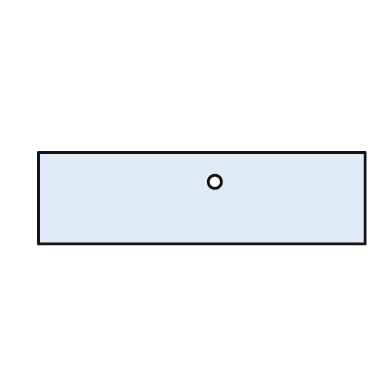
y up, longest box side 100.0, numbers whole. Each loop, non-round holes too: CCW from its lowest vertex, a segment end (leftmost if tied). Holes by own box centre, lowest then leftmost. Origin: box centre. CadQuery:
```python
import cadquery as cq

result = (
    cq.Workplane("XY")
    .moveTo(-50.0, -14.0)
    .lineTo(50.0, -14.0)
    .lineTo(50.0, 14.0)
    .lineTo(-50.0, 14.0)
    .close()
    .moveTo(4.0, 5.0)
    .circle(2.0)
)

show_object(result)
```